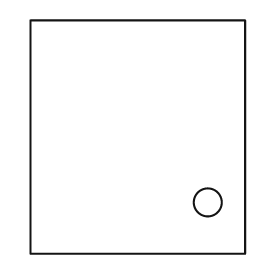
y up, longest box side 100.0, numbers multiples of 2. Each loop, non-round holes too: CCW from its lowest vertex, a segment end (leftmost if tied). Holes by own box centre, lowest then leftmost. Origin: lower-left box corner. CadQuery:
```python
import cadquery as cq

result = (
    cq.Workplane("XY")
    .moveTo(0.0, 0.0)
    .lineTo(92.0, 0.0)
    .lineTo(92.0, 100.0)
    .lineTo(0.0, 100.0)
    .close()
    .moveTo(76.0, 22.0)
    .circle(6.0)
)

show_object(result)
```